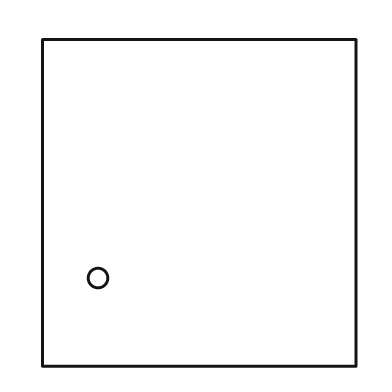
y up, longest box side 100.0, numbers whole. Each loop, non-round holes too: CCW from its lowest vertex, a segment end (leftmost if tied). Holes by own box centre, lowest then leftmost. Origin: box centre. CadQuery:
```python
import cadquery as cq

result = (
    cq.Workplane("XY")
    .moveTo(-48.0, -50.0)
    .lineTo(48.0, -50.0)
    .lineTo(48.0, 50.0)
    .lineTo(-48.0, 50.0)
    .close()
    .moveTo(-31.0, -23.0)
    .circle(3.0)
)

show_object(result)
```